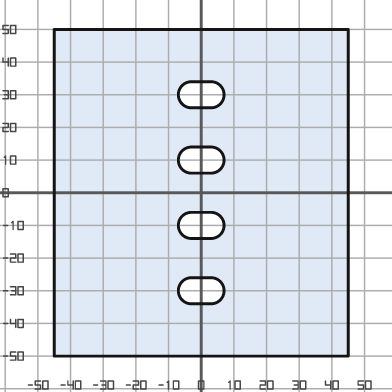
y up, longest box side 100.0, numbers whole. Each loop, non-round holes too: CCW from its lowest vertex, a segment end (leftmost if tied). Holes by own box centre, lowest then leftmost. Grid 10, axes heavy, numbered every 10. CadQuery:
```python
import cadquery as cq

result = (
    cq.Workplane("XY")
    .moveTo(-45.0, -50.0)
    .lineTo(45.0, -50.0)
    .lineTo(45.0, 50.0)
    .lineTo(-45.0, 50.0)
    .close()
    .moveTo(-3.0, -34.0)
    .lineTo(3.0, -34.0)
    .threePointArc((7.0, -30.0), (3.0, -26.0))
    .lineTo(-3.0, -26.0)
    .threePointArc((-7.0, -30.0), (-3.0, -34.0))
    .close()
    .moveTo(-3.0, -14.0)
    .lineTo(3.0, -14.0)
    .threePointArc((7.0, -10.0), (3.0, -6.0))
    .lineTo(-3.0, -6.0)
    .threePointArc((-7.0, -10.0), (-3.0, -14.0))
    .close()
    .moveTo(-3.0, 6.0)
    .lineTo(3.0, 6.0)
    .threePointArc((7.0, 10.0), (3.0, 14.0))
    .lineTo(-3.0, 14.0)
    .threePointArc((-7.0, 10.0), (-3.0, 6.0))
    .close()
    .moveTo(-3.0, 26.0)
    .lineTo(3.0, 26.0)
    .threePointArc((7.0, 30.0), (3.0, 34.0))
    .lineTo(-3.0, 34.0)
    .threePointArc((-7.0, 30.0), (-3.0, 26.0))
    .close()
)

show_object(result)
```